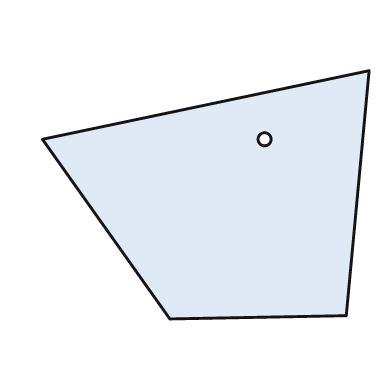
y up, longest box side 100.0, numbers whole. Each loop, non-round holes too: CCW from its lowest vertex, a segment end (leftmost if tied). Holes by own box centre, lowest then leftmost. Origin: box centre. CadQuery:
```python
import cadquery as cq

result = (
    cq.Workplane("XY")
    .moveTo(-11.0, -38.0)
    .lineTo(43.0, -37.0)
    .lineTo(50.0, 38.0)
    .lineTo(-50.0, 17.0)
    .close()
    .moveTo(18.0, 17.0)
    .circle(2.0)
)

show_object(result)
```